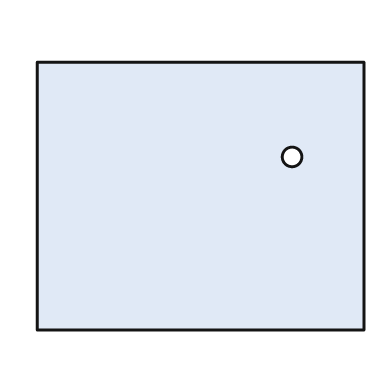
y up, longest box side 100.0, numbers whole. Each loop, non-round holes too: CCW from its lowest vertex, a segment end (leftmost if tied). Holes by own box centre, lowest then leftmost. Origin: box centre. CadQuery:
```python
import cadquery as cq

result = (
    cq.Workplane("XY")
    .moveTo(-50.0, -41.0)
    .lineTo(50.0, -41.0)
    .lineTo(50.0, 41.0)
    .lineTo(-50.0, 41.0)
    .close()
    .moveTo(28.0, 12.0)
    .circle(3.0)
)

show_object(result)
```